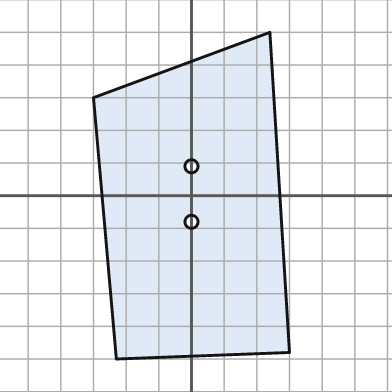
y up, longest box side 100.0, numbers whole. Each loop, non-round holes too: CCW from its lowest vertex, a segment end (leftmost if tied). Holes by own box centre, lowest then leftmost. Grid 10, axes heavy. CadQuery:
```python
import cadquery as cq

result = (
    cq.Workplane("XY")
    .moveTo(-23.0, -50.0)
    .lineTo(30.0, -48.0)
    .lineTo(24.0, 50.0)
    .lineTo(-30.0, 30.0)
    .close()
    .moveTo(0.0, -8.0)
    .circle(2.0)
    .moveTo(0.0, 9.0)
    .circle(2.0)
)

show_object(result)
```